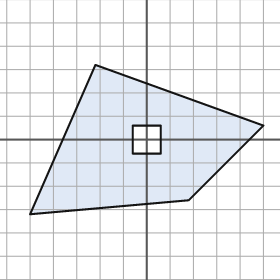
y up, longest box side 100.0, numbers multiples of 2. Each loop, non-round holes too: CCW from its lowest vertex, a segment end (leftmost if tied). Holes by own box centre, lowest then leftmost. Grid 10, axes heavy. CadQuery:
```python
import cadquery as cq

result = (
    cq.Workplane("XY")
    .moveTo(-50.0, -32.0)
    .lineTo(18.0, -26.0)
    .lineTo(50.0, 6.0)
    .lineTo(-22.0, 32.0)
    .close()
    .moveTo(-6.0, -6.0)
    .lineTo(6.0, -6.0)
    .lineTo(6.0, 6.0)
    .lineTo(-6.0, 6.0)
    .close()
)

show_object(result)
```